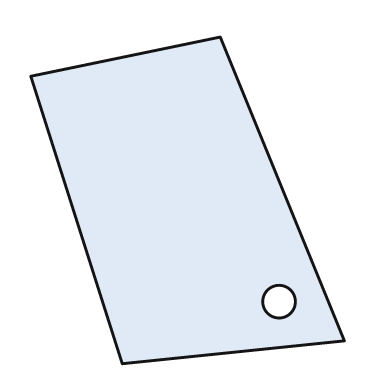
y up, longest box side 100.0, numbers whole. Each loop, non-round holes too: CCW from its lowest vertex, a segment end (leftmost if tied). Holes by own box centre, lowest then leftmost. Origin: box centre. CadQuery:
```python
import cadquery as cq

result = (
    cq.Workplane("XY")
    .moveTo(-20.0, -50.0)
    .lineTo(48.0, -43.0)
    .lineTo(10.0, 50.0)
    .lineTo(-48.0, 38.0)
    .close()
    .moveTo(28.0, -31.0)
    .circle(5.0)
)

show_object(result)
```